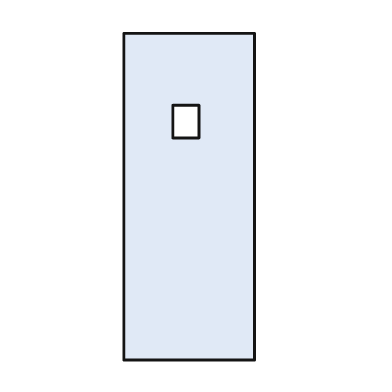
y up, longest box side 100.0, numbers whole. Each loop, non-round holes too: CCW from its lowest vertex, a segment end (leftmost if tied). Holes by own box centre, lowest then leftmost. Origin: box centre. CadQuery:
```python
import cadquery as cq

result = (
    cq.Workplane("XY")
    .moveTo(-20.0, -50.0)
    .lineTo(20.0, -50.0)
    .lineTo(20.0, 50.0)
    .lineTo(-20.0, 50.0)
    .close()
    .moveTo(-5.0, 18.0)
    .lineTo(3.0, 18.0)
    .lineTo(3.0, 28.0)
    .lineTo(-5.0, 28.0)
    .close()
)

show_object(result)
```